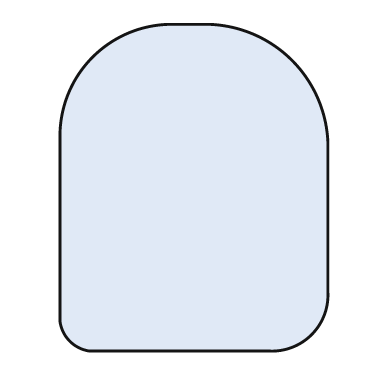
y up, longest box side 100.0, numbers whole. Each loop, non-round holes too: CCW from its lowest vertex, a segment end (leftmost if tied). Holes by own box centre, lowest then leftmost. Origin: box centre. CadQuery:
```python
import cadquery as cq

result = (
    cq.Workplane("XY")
    .moveTo(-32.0, -50.0)
    .lineTo(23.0, -50.0)
    .threePointArc((36.0, -45.0), (41.0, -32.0))
    .lineTo(41.0, 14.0)
    .threePointArc((30.0, 39.0), (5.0, 50.0))
    .lineTo(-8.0, 50.0)
    .threePointArc((-31.0, 40.0), (-41.0, 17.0))
    .lineTo(-41.0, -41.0)
    .threePointArc((-38.0, -47.0), (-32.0, -50.0))
    .close()
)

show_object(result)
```